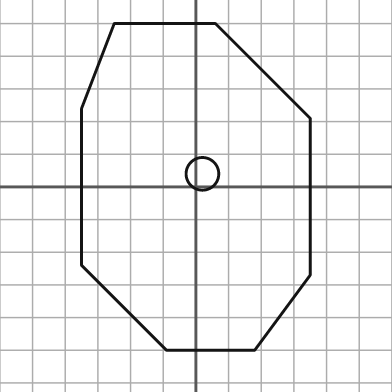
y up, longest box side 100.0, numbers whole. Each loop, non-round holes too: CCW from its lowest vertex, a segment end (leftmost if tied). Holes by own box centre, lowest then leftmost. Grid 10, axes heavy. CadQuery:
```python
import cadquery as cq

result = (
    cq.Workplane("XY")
    .moveTo(-9.0, -50.0)
    .lineTo(18.0, -50.0)
    .lineTo(35.0, -27.0)
    .lineTo(35.0, 21.0)
    .lineTo(6.0, 50.0)
    .lineTo(-25.0, 50.0)
    .lineTo(-35.0, 24.0)
    .lineTo(-35.0, -24.0)
    .close()
    .moveTo(2.0, 4.0)
    .circle(5.0)
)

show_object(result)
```